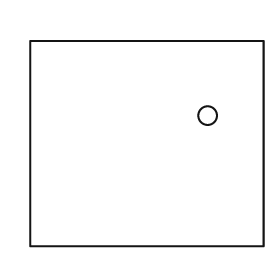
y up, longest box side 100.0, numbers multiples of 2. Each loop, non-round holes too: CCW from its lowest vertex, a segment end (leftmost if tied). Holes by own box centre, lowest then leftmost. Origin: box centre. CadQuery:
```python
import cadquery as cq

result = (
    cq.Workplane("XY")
    .moveTo(-50.0, -44.0)
    .lineTo(50.0, -44.0)
    .lineTo(50.0, 44.0)
    .lineTo(-50.0, 44.0)
    .close()
    .moveTo(26.0, 12.0)
    .circle(4.0)
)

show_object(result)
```